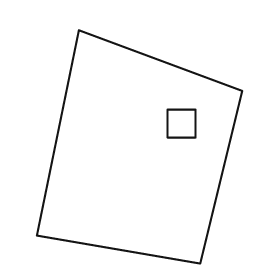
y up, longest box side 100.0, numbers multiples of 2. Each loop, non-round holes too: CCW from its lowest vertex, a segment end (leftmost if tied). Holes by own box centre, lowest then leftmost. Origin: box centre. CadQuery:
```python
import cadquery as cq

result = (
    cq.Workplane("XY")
    .moveTo(26.0, -50.0)
    .lineTo(44.0, 24.0)
    .lineTo(-26.0, 50.0)
    .lineTo(-44.0, -38.0)
    .close()
    .moveTo(12.0, 4.0)
    .lineTo(24.0, 4.0)
    .lineTo(24.0, 16.0)
    .lineTo(12.0, 16.0)
    .close()
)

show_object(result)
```